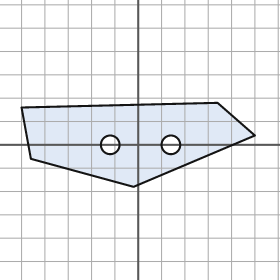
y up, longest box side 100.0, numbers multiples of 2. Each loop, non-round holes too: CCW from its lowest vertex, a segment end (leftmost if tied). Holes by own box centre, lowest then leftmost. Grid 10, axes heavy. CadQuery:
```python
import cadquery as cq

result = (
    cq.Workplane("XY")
    .moveTo(-2.0, -18.0)
    .lineTo(50.0, 4.0)
    .lineTo(34.0, 18.0)
    .lineTo(-50.0, 16.0)
    .lineTo(-46.0, -6.0)
    .close()
    .moveTo(-12.0, 0.0)
    .circle(4.0)
    .moveTo(14.0, 0.0)
    .circle(4.0)
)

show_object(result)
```